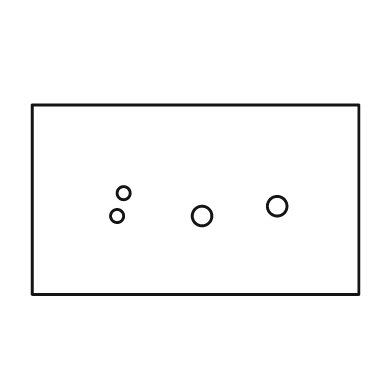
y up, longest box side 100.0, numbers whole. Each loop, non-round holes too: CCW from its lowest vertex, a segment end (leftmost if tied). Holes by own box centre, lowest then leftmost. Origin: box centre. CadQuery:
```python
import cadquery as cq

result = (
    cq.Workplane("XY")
    .moveTo(-50.0, -29.0)
    .lineTo(50.0, -29.0)
    .lineTo(50.0, 29.0)
    .lineTo(-50.0, 29.0)
    .close()
    .moveTo(-24.0, -5.0)
    .circle(2.0)
    .moveTo(2.0, -5.0)
    .circle(3.0)
    .moveTo(25.0, -2.0)
    .circle(3.0)
    .moveTo(-22.0, 2.0)
    .circle(2.0)
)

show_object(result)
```